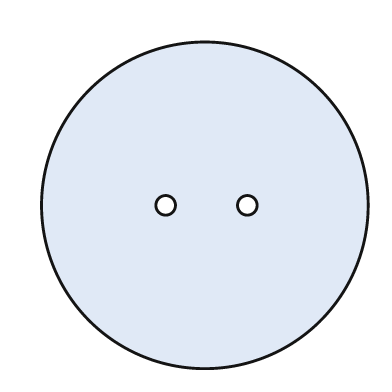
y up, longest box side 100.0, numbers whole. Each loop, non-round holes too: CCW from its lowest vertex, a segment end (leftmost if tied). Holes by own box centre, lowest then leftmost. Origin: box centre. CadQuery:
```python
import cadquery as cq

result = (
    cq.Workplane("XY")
    .moveTo(0.0, 0.0)
    .circle(50.0)
    .moveTo(-12.0, 0.0)
    .circle(3.0)
    .moveTo(13.0, 0.0)
    .circle(3.0)
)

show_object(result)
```